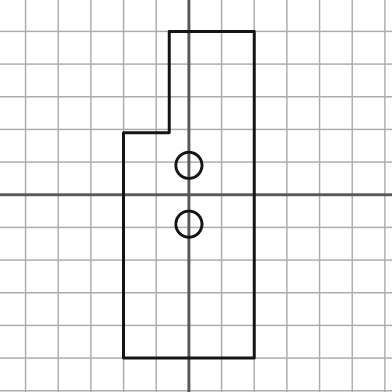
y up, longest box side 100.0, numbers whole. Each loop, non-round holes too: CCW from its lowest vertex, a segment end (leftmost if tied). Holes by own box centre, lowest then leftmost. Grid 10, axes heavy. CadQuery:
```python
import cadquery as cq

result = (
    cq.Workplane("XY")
    .moveTo(-20.0, -50.0)
    .lineTo(20.0, -50.0)
    .lineTo(20.0, 50.0)
    .lineTo(-6.0, 50.0)
    .lineTo(-6.0, 19.0)
    .lineTo(-20.0, 19.0)
    .close()
    .moveTo(0.0, -9.0)
    .circle(4.0)
    .moveTo(0.0, 9.0)
    .circle(4.0)
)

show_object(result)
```